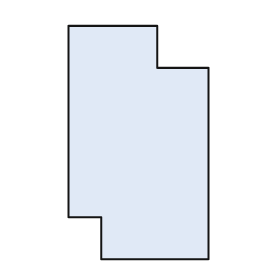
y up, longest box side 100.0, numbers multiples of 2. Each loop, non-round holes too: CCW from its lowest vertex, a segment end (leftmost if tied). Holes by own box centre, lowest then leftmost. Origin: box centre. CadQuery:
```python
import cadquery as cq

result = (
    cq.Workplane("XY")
    .moveTo(-16.0, -50.0)
    .lineTo(30.0, -50.0)
    .lineTo(30.0, 32.0)
    .lineTo(8.0, 32.0)
    .lineTo(8.0, 50.0)
    .lineTo(-30.0, 50.0)
    .lineTo(-30.0, -32.0)
    .lineTo(-16.0, -32.0)
    .close()
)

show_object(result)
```